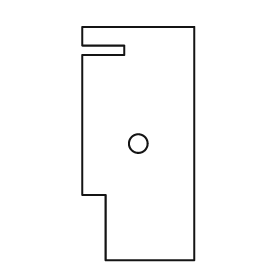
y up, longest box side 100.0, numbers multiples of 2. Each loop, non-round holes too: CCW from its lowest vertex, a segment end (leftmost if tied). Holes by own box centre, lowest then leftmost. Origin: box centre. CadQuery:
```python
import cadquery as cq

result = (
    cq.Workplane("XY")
    .moveTo(-14.0, -50.0)
    .lineTo(24.0, -50.0)
    .lineTo(24.0, 50.0)
    .lineTo(-24.0, 50.0)
    .lineTo(-24.0, 42.0)
    .lineTo(-6.0, 42.0)
    .lineTo(-6.0, 38.0)
    .lineTo(-24.0, 38.0)
    .lineTo(-24.0, -22.0)
    .lineTo(-14.0, -22.0)
    .close()
    .moveTo(0.0, 0.0)
    .circle(4.0)
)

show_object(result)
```